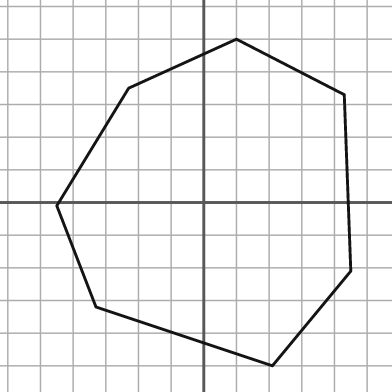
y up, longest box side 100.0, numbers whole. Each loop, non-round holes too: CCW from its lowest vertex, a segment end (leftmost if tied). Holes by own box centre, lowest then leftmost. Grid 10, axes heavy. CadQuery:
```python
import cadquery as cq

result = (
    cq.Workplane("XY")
    .moveTo(21.0, -50.0)
    .lineTo(45.0, -21.0)
    .lineTo(43.0, 33.0)
    .lineTo(10.0, 50.0)
    .lineTo(-23.0, 35.0)
    .lineTo(-45.0, -1.0)
    .lineTo(-33.0, -32.0)
    .close()
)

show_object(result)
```